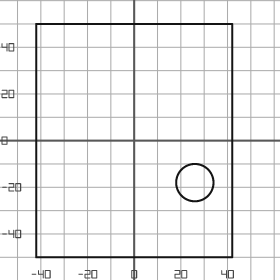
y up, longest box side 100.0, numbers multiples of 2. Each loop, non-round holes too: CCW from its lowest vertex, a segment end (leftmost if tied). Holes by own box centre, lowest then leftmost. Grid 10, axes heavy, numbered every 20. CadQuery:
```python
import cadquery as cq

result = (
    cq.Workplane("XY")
    .moveTo(-42.0, -50.0)
    .lineTo(42.0, -50.0)
    .lineTo(42.0, 50.0)
    .lineTo(-42.0, 50.0)
    .close()
    .moveTo(26.0, -18.0)
    .circle(8.0)
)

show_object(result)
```